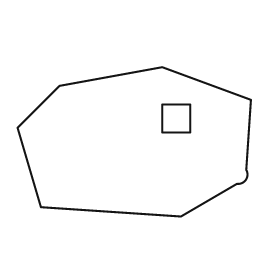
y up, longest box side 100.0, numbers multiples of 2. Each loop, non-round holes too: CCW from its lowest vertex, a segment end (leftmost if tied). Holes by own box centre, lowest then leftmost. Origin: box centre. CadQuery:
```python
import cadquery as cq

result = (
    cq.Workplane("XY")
    .moveTo(20.0, -32.0)
    .lineTo(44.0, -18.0)
    .threePointArc((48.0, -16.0), (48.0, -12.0))
    .lineTo(50.0, 18.0)
    .lineTo(12.0, 32.0)
    .lineTo(-32.0, 24.0)
    .lineTo(-50.0, 6.0)
    .lineTo(-40.0, -28.0)
    .close()
    .moveTo(12.0, 4.0)
    .lineTo(24.0, 4.0)
    .lineTo(24.0, 16.0)
    .lineTo(12.0, 16.0)
    .close()
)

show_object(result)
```